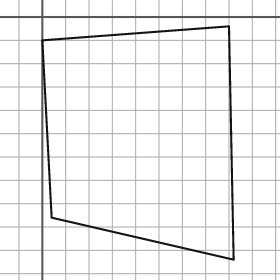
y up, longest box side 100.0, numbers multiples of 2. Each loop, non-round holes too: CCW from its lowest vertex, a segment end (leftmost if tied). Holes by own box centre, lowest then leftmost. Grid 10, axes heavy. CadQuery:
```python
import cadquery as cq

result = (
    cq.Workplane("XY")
    .moveTo(82.0, -104.0)
    .lineTo(80.0, -4.0)
    .lineTo(0.0, -10.0)
    .lineTo(4.0, -86.0)
    .close()
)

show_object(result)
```